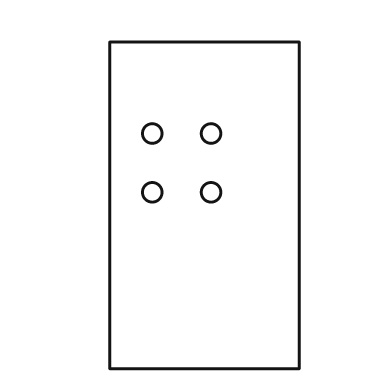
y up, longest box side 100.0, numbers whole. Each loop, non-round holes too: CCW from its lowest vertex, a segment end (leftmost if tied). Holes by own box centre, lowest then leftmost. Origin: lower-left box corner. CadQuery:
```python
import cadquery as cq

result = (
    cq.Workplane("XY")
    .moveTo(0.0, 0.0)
    .lineTo(58.0, 0.0)
    .lineTo(58.0, 100.0)
    .lineTo(0.0, 100.0)
    .close()
    .moveTo(13.0, 54.0)
    .circle(3.0)
    .moveTo(31.0, 54.0)
    .circle(3.0)
    .moveTo(13.0, 72.0)
    .circle(3.0)
    .moveTo(31.0, 72.0)
    .circle(3.0)
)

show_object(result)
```